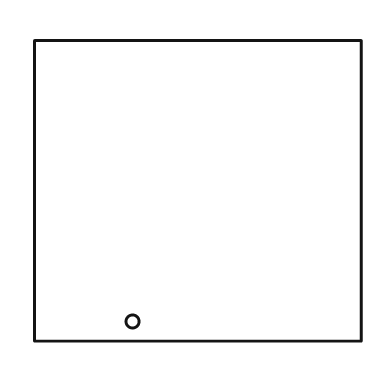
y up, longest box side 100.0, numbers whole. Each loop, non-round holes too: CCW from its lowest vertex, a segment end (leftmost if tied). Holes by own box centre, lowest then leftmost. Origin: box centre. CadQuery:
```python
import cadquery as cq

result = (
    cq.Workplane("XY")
    .moveTo(-50.0, -46.0)
    .lineTo(50.0, -46.0)
    .lineTo(50.0, 46.0)
    .lineTo(-50.0, 46.0)
    .close()
    .moveTo(-20.0, -40.0)
    .circle(2.0)
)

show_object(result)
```